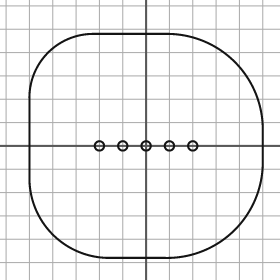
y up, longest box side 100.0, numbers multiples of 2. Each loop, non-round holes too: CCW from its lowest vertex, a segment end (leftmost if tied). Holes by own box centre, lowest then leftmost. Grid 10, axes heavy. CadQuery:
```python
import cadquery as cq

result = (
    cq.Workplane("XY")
    .moveTo(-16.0, -48.0)
    .lineTo(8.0, -48.0)
    .threePointArc((38.0, -36.0), (50.0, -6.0))
    .lineTo(50.0, 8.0)
    .threePointArc((38.0, 36.0), (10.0, 48.0))
    .lineTo(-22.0, 48.0)
    .threePointArc((-42.0, 40.0), (-50.0, 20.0))
    .lineTo(-50.0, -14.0)
    .threePointArc((-40.0, -38.0), (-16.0, -48.0))
    .close()
    .moveTo(-20.0, 0.0)
    .circle(2.0)
    .moveTo(-10.0, 0.0)
    .circle(2.0)
    .moveTo(0.0, 0.0)
    .circle(2.0)
    .moveTo(10.0, 0.0)
    .circle(2.0)
    .moveTo(20.0, 0.0)
    .circle(2.0)
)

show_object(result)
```